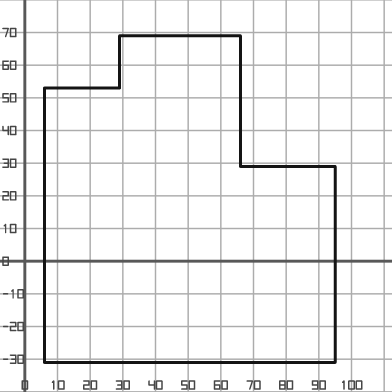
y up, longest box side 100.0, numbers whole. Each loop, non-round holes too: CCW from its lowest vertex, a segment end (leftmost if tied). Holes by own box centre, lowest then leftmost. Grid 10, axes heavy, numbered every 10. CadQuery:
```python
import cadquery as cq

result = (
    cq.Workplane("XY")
    .moveTo(6.0, -31.0)
    .lineTo(95.0, -31.0)
    .lineTo(95.0, 29.0)
    .lineTo(66.0, 29.0)
    .lineTo(66.0, 69.0)
    .lineTo(29.0, 69.0)
    .lineTo(29.0, 53.0)
    .lineTo(6.0, 53.0)
    .close()
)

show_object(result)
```